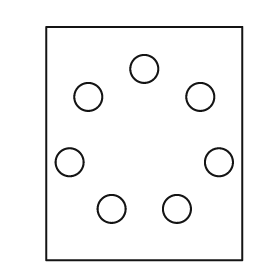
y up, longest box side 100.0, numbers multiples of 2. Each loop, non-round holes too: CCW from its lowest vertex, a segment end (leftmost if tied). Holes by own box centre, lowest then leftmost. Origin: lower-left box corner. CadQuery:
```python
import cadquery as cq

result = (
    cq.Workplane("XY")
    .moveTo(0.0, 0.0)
    .lineTo(84.0, 0.0)
    .lineTo(84.0, 100.0)
    .lineTo(0.0, 100.0)
    .close()
    .moveTo(28.0, 22.0)
    .circle(6.0)
    .moveTo(56.0, 22.0)
    .circle(6.0)
    .moveTo(10.0, 42.0)
    .circle(6.0)
    .moveTo(74.0, 42.0)
    .circle(6.0)
    .moveTo(18.0, 70.0)
    .circle(6.0)
    .moveTo(66.0, 70.0)
    .circle(6.0)
    .moveTo(42.0, 82.0)
    .circle(6.0)
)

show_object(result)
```